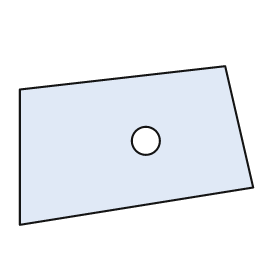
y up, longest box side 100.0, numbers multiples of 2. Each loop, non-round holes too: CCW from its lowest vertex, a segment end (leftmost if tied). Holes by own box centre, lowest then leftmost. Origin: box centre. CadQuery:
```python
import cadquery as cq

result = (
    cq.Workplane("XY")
    .moveTo(-50.0, -34.0)
    .lineTo(50.0, -18.0)
    .lineTo(38.0, 34.0)
    .lineTo(-50.0, 24.0)
    .close()
    .moveTo(4.0, 2.0)
    .circle(6.0)
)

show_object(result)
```